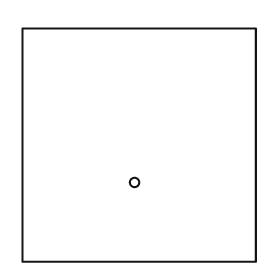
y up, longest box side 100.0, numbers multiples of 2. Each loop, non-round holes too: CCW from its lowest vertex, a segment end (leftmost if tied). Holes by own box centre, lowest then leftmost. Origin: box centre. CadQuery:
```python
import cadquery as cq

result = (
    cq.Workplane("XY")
    .moveTo(-50.0, -50.0)
    .lineTo(50.0, -50.0)
    .lineTo(50.0, 50.0)
    .lineTo(-50.0, 50.0)
    .close()
    .moveTo(-2.0, -16.0)
    .circle(2.0)
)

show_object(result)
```